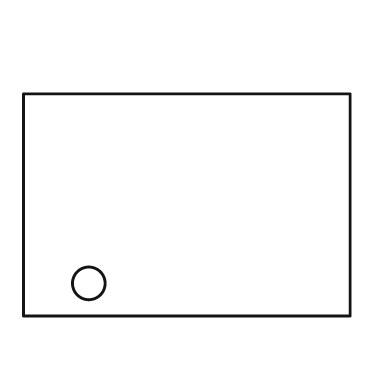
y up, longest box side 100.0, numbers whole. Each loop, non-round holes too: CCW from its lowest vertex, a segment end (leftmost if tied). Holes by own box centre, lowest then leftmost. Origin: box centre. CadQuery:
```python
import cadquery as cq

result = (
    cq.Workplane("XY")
    .moveTo(-50.0, -34.0)
    .lineTo(50.0, -34.0)
    .lineTo(50.0, 34.0)
    .lineTo(-50.0, 34.0)
    .close()
    .moveTo(-30.0, -24.0)
    .circle(5.0)
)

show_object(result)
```